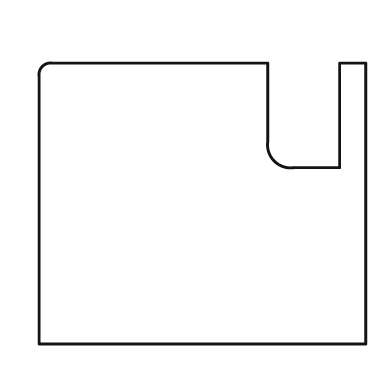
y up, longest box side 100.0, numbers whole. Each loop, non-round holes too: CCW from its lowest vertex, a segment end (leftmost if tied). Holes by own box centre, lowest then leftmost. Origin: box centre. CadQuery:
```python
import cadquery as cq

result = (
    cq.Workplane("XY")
    .moveTo(-50.0, -43.0)
    .lineTo(50.0, -43.0)
    .lineTo(50.0, 43.0)
    .lineTo(42.0, 43.0)
    .lineTo(42.0, 11.0)
    .lineTo(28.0, 11.0)
    .threePointArc((22.0, 13.0), (20.0, 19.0))
    .lineTo(20.0, 43.0)
    .lineTo(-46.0, 43.0)
    .threePointArc((-49.0, 42.0), (-50.0, 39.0))
    .close()
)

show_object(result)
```